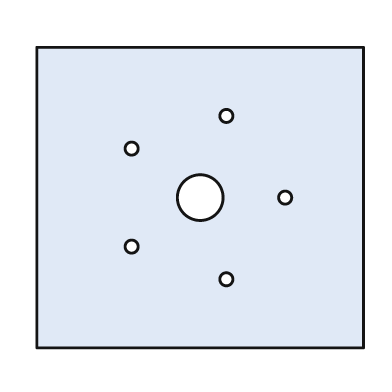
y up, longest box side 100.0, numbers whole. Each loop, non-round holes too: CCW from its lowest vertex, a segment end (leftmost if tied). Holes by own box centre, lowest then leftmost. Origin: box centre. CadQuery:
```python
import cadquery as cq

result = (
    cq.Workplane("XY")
    .moveTo(-50.0, -46.0)
    .lineTo(50.0, -46.0)
    .lineTo(50.0, 46.0)
    .lineTo(-50.0, 46.0)
    .close()
    .moveTo(8.0, -25.0)
    .circle(2.0)
    .moveTo(-21.0, -15.0)
    .circle(2.0)
    .moveTo(0.0, 0.0)
    .circle(7.0)
    .moveTo(26.0, 0.0)
    .circle(2.0)
    .moveTo(-21.0, 15.0)
    .circle(2.0)
    .moveTo(8.0, 25.0)
    .circle(2.0)
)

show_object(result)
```